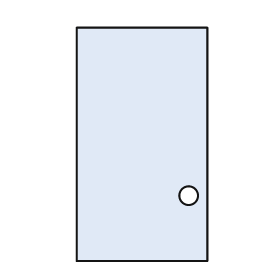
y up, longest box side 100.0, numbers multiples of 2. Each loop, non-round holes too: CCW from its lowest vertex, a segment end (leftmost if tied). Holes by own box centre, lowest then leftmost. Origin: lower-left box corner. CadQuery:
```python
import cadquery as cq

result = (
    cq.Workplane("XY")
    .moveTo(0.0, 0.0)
    .lineTo(56.0, 0.0)
    .lineTo(56.0, 100.0)
    .lineTo(0.0, 100.0)
    .close()
    .moveTo(48.0, 28.0)
    .circle(4.0)
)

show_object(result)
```